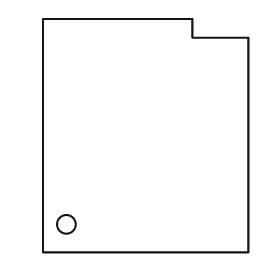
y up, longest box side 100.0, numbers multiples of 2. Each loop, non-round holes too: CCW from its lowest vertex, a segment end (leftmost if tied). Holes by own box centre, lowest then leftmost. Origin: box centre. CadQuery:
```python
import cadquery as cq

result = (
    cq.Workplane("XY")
    .moveTo(-44.0, -50.0)
    .lineTo(44.0, -50.0)
    .lineTo(44.0, 42.0)
    .lineTo(20.0, 42.0)
    .lineTo(20.0, 50.0)
    .lineTo(-44.0, 50.0)
    .close()
    .moveTo(-34.0, -38.0)
    .circle(4.0)
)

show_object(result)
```